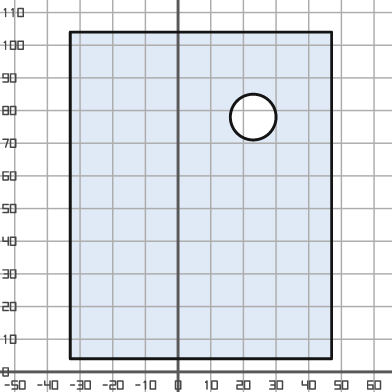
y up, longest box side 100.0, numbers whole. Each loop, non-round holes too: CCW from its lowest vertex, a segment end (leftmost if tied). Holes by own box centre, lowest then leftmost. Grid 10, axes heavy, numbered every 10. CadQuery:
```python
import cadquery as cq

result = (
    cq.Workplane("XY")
    .moveTo(-33.0, 4.0)
    .lineTo(47.0, 4.0)
    .lineTo(47.0, 104.0)
    .lineTo(-33.0, 104.0)
    .close()
    .moveTo(23.0, 78.0)
    .circle(7.0)
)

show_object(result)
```